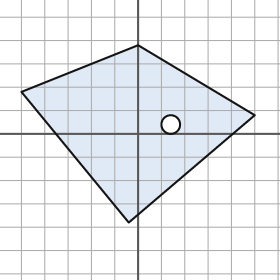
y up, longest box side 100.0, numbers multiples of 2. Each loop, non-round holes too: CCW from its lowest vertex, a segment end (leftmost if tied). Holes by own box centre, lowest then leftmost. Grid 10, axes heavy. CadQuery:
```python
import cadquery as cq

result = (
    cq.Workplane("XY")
    .moveTo(-4.0, -38.0)
    .lineTo(50.0, 8.0)
    .lineTo(0.0, 38.0)
    .lineTo(-50.0, 18.0)
    .close()
    .moveTo(14.0, 4.0)
    .circle(4.0)
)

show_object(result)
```